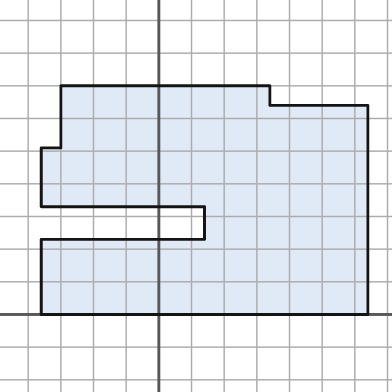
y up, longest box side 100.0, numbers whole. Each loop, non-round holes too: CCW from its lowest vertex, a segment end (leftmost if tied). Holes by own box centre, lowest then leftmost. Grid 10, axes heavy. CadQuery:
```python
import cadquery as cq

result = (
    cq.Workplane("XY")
    .moveTo(-36.0, 0.0)
    .lineTo(64.0, 0.0)
    .lineTo(64.0, 64.0)
    .lineTo(34.0, 64.0)
    .lineTo(34.0, 70.0)
    .lineTo(-30.0, 70.0)
    .lineTo(-30.0, 51.0)
    .lineTo(-36.0, 51.0)
    .lineTo(-36.0, 33.0)
    .lineTo(14.0, 33.0)
    .lineTo(14.0, 23.0)
    .lineTo(-36.0, 23.0)
    .close()
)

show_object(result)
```